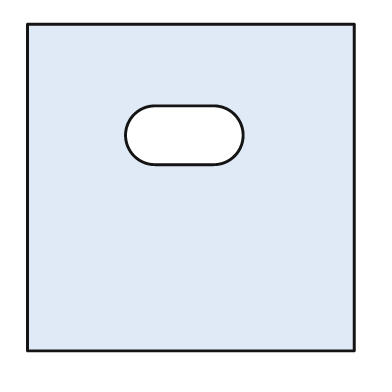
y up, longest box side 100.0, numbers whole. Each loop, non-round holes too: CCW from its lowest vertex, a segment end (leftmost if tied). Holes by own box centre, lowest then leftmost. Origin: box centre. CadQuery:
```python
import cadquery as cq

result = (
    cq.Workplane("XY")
    .moveTo(-50.0, -50.0)
    .lineTo(50.0, -50.0)
    .lineTo(50.0, 50.0)
    .lineTo(-50.0, 50.0)
    .close()
    .moveTo(-11.0, 7.0)
    .lineTo(7.0, 7.0)
    .threePointArc((16.0, 16.0), (7.0, 25.0))
    .lineTo(-11.0, 25.0)
    .threePointArc((-20.0, 16.0), (-11.0, 7.0))
    .close()
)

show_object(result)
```